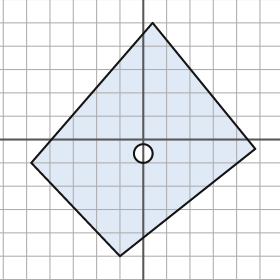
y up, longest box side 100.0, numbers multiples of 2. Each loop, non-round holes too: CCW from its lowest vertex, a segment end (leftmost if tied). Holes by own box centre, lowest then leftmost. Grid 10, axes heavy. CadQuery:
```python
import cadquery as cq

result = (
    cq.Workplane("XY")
    .moveTo(-10.0, -50.0)
    .lineTo(48.0, -4.0)
    .lineTo(4.0, 50.0)
    .lineTo(-48.0, -10.0)
    .close()
    .moveTo(0.0, -6.0)
    .circle(4.0)
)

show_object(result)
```